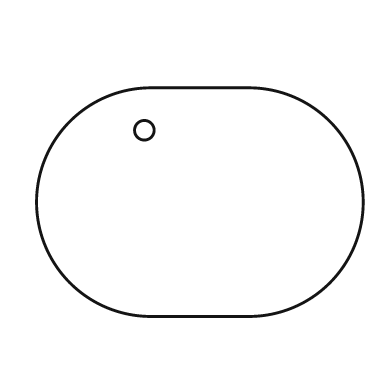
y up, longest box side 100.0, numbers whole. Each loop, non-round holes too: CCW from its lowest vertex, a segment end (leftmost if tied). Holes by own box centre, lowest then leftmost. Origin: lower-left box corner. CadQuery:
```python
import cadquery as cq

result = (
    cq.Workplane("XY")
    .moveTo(35.0, 0.0)
    .lineTo(65.0, 0.0)
    .threePointArc((100.0, 35.0), (65.0, 70.0))
    .lineTo(35.0, 70.0)
    .threePointArc((0.0, 35.0), (35.0, 0.0))
    .close()
    .moveTo(33.0, 57.0)
    .circle(3.0)
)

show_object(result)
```